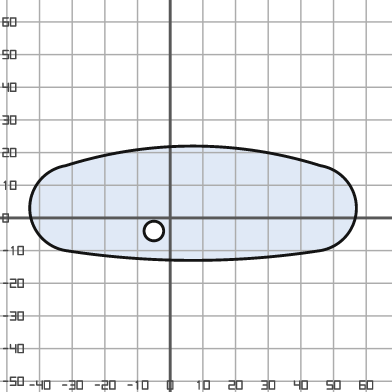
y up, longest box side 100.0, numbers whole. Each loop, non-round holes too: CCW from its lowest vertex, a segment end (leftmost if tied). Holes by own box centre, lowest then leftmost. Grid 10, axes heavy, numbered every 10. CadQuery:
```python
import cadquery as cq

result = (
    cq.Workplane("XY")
    .moveTo(-32.0, -10.0)
    .threePointArc((7.0, -13.0), (46.0, -10.0))
    .threePointArc((57.0, 3.0), (46.0, 16.0))
    .threePointArc((7.0, 22.0), (-32.0, 16.0))
    .threePointArc((-43.0, 3.0), (-32.0, -10.0))
    .close()
    .moveTo(-5.0, -4.0)
    .circle(3.0)
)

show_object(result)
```